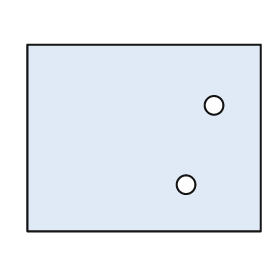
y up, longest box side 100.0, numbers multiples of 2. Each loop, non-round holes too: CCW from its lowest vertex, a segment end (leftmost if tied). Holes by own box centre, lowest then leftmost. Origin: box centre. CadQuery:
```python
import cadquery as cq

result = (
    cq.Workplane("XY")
    .moveTo(-50.0, -40.0)
    .lineTo(50.0, -40.0)
    .lineTo(50.0, 40.0)
    .lineTo(-50.0, 40.0)
    .close()
    .moveTo(18.0, -20.0)
    .circle(4.0)
    .moveTo(30.0, 14.0)
    .circle(4.0)
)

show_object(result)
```